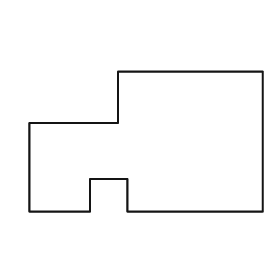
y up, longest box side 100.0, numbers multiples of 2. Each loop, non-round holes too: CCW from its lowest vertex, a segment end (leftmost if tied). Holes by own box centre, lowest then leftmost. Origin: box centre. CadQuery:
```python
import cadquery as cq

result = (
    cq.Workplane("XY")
    .moveTo(-50.0, -30.0)
    .lineTo(-24.0, -30.0)
    .lineTo(-24.0, -16.0)
    .lineTo(-8.0, -16.0)
    .lineTo(-8.0, -30.0)
    .lineTo(50.0, -30.0)
    .lineTo(50.0, 30.0)
    .lineTo(-12.0, 30.0)
    .lineTo(-12.0, 8.0)
    .lineTo(-50.0, 8.0)
    .close()
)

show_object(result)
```